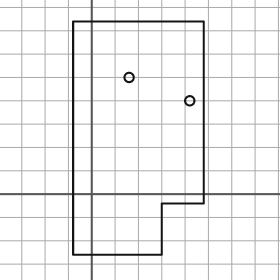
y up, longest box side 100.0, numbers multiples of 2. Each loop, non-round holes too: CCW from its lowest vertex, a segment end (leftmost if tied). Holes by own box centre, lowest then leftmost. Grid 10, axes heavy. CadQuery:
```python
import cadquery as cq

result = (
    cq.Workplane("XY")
    .moveTo(-8.0, -26.0)
    .lineTo(30.0, -26.0)
    .lineTo(30.0, -4.0)
    .lineTo(48.0, -4.0)
    .lineTo(48.0, 74.0)
    .lineTo(-8.0, 74.0)
    .close()
    .moveTo(42.0, 40.0)
    .circle(2.0)
    .moveTo(16.0, 50.0)
    .circle(2.0)
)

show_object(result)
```